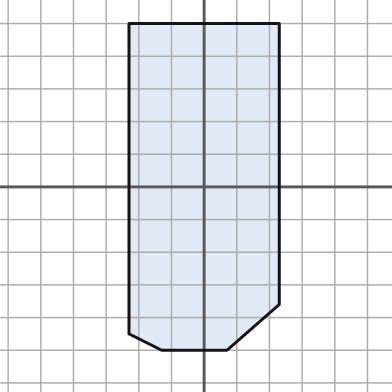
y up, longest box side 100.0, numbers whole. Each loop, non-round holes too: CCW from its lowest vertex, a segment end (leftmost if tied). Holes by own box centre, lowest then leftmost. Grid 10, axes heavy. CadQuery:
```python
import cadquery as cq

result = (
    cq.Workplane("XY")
    .moveTo(-13.0, -50.0)
    .lineTo(7.0, -50.0)
    .lineTo(23.0, -36.0)
    .lineTo(23.0, 50.0)
    .lineTo(-23.0, 50.0)
    .lineTo(-23.0, -45.0)
    .close()
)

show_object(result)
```